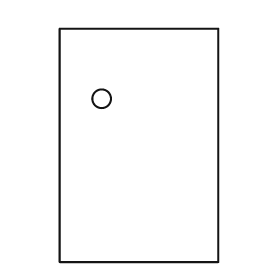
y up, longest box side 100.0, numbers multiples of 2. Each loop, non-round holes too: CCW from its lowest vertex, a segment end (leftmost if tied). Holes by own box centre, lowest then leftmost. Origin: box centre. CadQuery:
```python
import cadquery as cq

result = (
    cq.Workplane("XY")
    .moveTo(-34.0, -50.0)
    .lineTo(34.0, -50.0)
    .lineTo(34.0, 50.0)
    .lineTo(-34.0, 50.0)
    .close()
    .moveTo(-16.0, 20.0)
    .circle(4.0)
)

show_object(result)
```